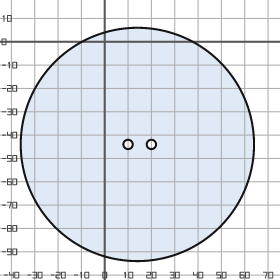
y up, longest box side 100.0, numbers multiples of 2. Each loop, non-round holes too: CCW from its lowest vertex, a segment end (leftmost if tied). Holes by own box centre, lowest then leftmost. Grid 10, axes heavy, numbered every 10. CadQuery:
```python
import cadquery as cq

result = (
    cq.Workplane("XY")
    .moveTo(14.0, -44.0)
    .circle(50.0)
    .moveTo(10.0, -44.0)
    .circle(2.0)
    .moveTo(20.0, -44.0)
    .circle(2.0)
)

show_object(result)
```